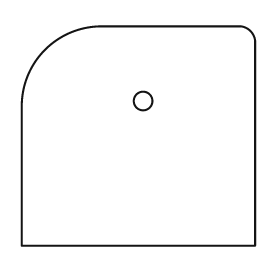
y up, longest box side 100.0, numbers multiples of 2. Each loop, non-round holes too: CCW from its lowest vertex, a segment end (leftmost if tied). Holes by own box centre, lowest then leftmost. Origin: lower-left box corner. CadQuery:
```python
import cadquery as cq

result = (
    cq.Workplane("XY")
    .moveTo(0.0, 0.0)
    .lineTo(100.0, 0.0)
    .lineTo(100.0, 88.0)
    .threePointArc((98.0, 92.0), (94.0, 94.0))
    .lineTo(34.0, 94.0)
    .threePointArc((10.0, 84.0), (0.0, 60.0))
    .close()
    .moveTo(52.0, 62.0)
    .circle(4.0)
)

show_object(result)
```